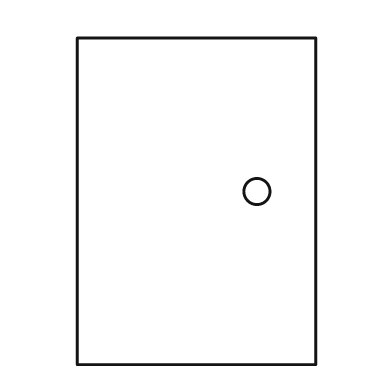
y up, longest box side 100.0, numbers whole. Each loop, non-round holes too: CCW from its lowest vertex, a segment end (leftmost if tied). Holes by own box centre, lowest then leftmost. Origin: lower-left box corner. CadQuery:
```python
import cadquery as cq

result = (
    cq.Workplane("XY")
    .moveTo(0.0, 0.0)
    .lineTo(73.0, 0.0)
    .lineTo(73.0, 100.0)
    .lineTo(0.0, 100.0)
    .close()
    .moveTo(55.0, 53.0)
    .circle(4.0)
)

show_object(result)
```